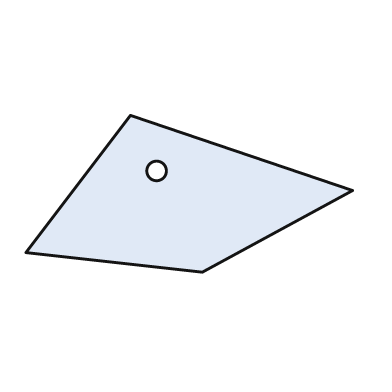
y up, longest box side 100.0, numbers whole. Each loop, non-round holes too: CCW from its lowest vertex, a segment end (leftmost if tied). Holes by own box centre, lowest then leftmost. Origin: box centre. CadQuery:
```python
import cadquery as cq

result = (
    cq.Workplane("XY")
    .moveTo(4.0, -24.0)
    .lineTo(50.0, 1.0)
    .lineTo(-18.0, 24.0)
    .lineTo(-50.0, -18.0)
    .close()
    .moveTo(-10.0, 7.0)
    .circle(3.0)
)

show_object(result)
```